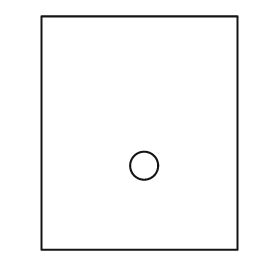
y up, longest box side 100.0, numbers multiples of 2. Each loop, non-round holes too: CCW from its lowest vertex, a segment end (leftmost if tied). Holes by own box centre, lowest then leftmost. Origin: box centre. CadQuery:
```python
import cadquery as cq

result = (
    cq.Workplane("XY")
    .moveTo(-42.0, -50.0)
    .lineTo(42.0, -50.0)
    .lineTo(42.0, 50.0)
    .lineTo(-42.0, 50.0)
    .close()
    .moveTo(2.0, -14.0)
    .circle(6.0)
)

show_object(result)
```